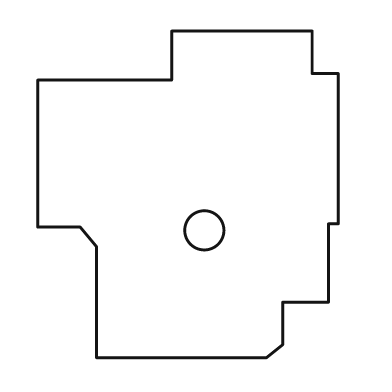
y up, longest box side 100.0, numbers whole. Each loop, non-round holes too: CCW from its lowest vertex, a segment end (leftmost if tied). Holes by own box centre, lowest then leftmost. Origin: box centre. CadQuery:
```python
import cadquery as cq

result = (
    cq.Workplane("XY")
    .moveTo(-28.0, -50.0)
    .lineTo(24.0, -50.0)
    .lineTo(29.0, -46.0)
    .lineTo(29.0, -33.0)
    .lineTo(43.0, -33.0)
    .lineTo(43.0, -9.0)
    .lineTo(46.0, -9.0)
    .lineTo(46.0, 37.0)
    .lineTo(38.0, 37.0)
    .lineTo(38.0, 50.0)
    .lineTo(-5.0, 50.0)
    .lineTo(-5.0, 35.0)
    .lineTo(-46.0, 35.0)
    .lineTo(-46.0, -10.0)
    .lineTo(-33.0, -10.0)
    .lineTo(-28.0, -16.0)
    .close()
    .moveTo(5.0, -11.0)
    .circle(6.0)
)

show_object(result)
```